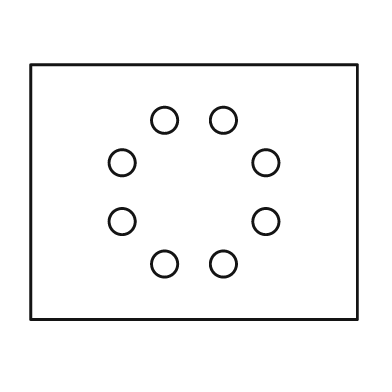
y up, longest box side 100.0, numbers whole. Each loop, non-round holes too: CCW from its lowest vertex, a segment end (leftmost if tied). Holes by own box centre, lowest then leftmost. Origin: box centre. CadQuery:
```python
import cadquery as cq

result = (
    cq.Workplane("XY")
    .moveTo(-50.0, -39.0)
    .lineTo(50.0, -39.0)
    .lineTo(50.0, 39.0)
    .lineTo(-50.0, 39.0)
    .close()
    .moveTo(-9.0, -22.0)
    .circle(4.0)
    .moveTo(9.0, -22.0)
    .circle(4.0)
    .moveTo(-22.0, -9.0)
    .circle(4.0)
    .moveTo(22.0, -9.0)
    .circle(4.0)
    .moveTo(-22.0, 9.0)
    .circle(4.0)
    .moveTo(22.0, 9.0)
    .circle(4.0)
    .moveTo(-9.0, 22.0)
    .circle(4.0)
    .moveTo(9.0, 22.0)
    .circle(4.0)
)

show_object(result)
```